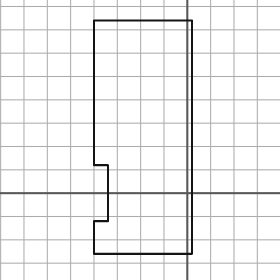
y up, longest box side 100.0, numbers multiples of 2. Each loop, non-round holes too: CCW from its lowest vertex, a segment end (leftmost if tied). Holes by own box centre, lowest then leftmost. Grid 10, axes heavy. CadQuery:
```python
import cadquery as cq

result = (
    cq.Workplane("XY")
    .moveTo(-40.0, -26.0)
    .lineTo(2.0, -26.0)
    .lineTo(2.0, 74.0)
    .lineTo(-40.0, 74.0)
    .lineTo(-40.0, 12.0)
    .lineTo(-34.0, 12.0)
    .lineTo(-34.0, -12.0)
    .lineTo(-40.0, -12.0)
    .close()
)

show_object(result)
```